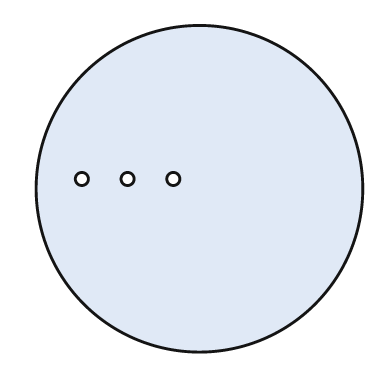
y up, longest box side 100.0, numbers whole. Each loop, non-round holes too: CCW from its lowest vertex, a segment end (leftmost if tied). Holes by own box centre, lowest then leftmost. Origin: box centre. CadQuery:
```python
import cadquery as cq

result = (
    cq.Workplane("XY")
    .moveTo(0.0, 0.0)
    .circle(50.0)
    .moveTo(-36.0, 3.0)
    .circle(2.0)
    .moveTo(-22.0, 3.0)
    .circle(2.0)
    .moveTo(-8.0, 3.0)
    .circle(2.0)
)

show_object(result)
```